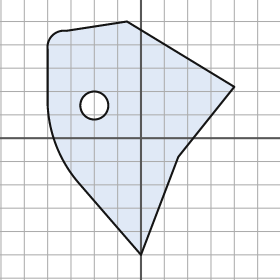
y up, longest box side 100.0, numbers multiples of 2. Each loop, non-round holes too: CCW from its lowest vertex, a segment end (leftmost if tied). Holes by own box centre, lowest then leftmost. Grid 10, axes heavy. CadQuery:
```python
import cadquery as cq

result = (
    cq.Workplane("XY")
    .moveTo(0.0, -50.0)
    .lineTo(16.0, -8.0)
    .lineTo(40.0, 22.0)
    .lineTo(-6.0, 50.0)
    .lineTo(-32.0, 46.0)
    .threePointArc((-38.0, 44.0), (-40.0, 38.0))
    .lineTo(-40.0, 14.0)
    .threePointArc((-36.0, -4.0), (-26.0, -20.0))
    .close()
    .moveTo(-20.0, 14.0)
    .circle(6.0)
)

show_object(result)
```